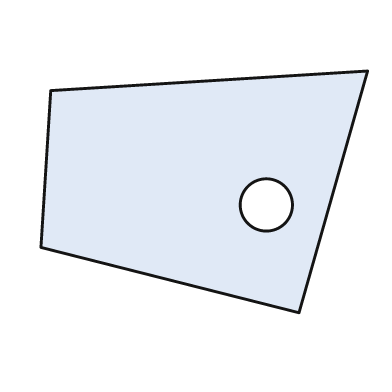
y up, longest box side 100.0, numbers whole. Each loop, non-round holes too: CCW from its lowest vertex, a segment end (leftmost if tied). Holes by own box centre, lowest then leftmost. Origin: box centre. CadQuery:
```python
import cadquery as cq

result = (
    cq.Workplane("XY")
    .moveTo(29.0, -37.0)
    .lineTo(50.0, 37.0)
    .lineTo(-47.0, 31.0)
    .lineTo(-50.0, -17.0)
    .close()
    .moveTo(19.0, -4.0)
    .circle(8.0)
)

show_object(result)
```